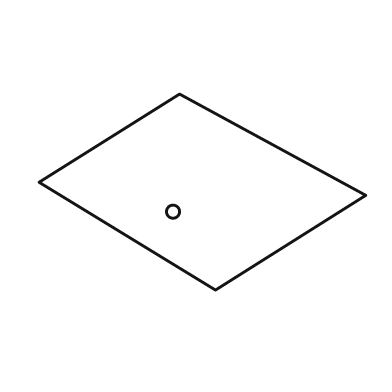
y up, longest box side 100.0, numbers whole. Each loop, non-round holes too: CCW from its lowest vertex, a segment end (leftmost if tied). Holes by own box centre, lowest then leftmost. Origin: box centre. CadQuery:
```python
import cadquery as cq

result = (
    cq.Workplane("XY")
    .moveTo(4.0, -30.0)
    .lineTo(50.0, -1.0)
    .lineTo(-7.0, 30.0)
    .lineTo(-50.0, 3.0)
    .close()
    .moveTo(-9.0, -6.0)
    .circle(2.0)
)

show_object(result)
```